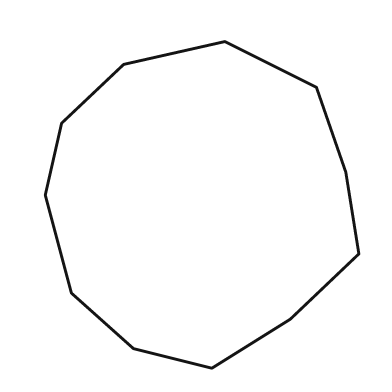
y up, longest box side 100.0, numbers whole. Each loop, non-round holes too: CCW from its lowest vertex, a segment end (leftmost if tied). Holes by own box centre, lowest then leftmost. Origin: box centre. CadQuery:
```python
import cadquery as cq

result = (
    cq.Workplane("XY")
    .moveTo(3.0, -50.0)
    .lineTo(27.0, -35.0)
    .lineTo(48.0, -15.0)
    .lineTo(44.0, 10.0)
    .lineTo(35.0, 36.0)
    .lineTo(7.0, 50.0)
    .lineTo(-24.0, 43.0)
    .lineTo(-43.0, 25.0)
    .lineTo(-48.0, 3.0)
    .lineTo(-40.0, -27.0)
    .lineTo(-21.0, -44.0)
    .close()
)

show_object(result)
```